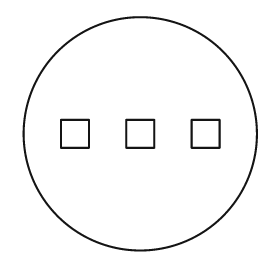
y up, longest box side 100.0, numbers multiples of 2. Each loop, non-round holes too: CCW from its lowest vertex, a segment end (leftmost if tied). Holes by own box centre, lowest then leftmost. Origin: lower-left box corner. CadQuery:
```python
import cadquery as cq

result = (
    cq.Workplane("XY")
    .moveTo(50.0, 50.0)
    .circle(50.0)
    .moveTo(16.0, 44.0)
    .lineTo(28.0, 44.0)
    .lineTo(28.0, 56.0)
    .lineTo(16.0, 56.0)
    .close()
    .moveTo(44.0, 44.0)
    .lineTo(56.0, 44.0)
    .lineTo(56.0, 56.0)
    .lineTo(44.0, 56.0)
    .close()
    .moveTo(72.0, 44.0)
    .lineTo(84.0, 44.0)
    .lineTo(84.0, 56.0)
    .lineTo(72.0, 56.0)
    .close()
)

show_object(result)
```